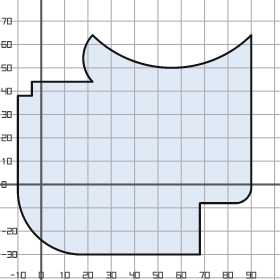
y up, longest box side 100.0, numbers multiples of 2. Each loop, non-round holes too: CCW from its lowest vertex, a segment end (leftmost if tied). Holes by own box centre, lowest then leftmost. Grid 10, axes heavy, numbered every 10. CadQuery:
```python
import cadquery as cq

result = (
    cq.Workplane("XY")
    .moveTo(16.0, -30.0)
    .lineTo(68.0, -30.0)
    .lineTo(68.0, -8.0)
    .lineTo(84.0, -8.0)
    .threePointArc((88.0, -6.0), (90.0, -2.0))
    .lineTo(90.0, 64.0)
    .threePointArc((56.0, 50.0), (22.0, 64.0))
    .threePointArc((18.0, 54.0), (22.0, 44.0))
    .lineTo(-4.0, 44.0)
    .lineTo(-4.0, 38.0)
    .lineTo(-10.0, 38.0)
    .lineTo(-10.0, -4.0)
    .threePointArc((-2.0, -22.0), (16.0, -30.0))
    .close()
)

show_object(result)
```